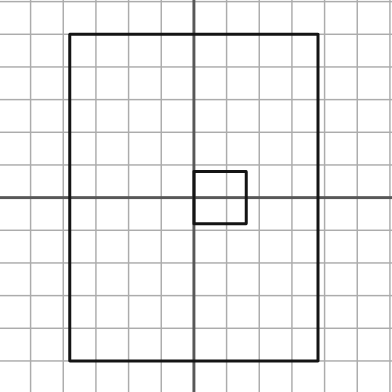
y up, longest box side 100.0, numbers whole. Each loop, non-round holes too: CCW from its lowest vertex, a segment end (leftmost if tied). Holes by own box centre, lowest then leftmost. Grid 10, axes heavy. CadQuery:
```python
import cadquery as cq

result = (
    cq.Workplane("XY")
    .moveTo(-38.0, -50.0)
    .lineTo(38.0, -50.0)
    .lineTo(38.0, 50.0)
    .lineTo(-38.0, 50.0)
    .close()
    .moveTo(0.0, -8.0)
    .lineTo(16.0, -8.0)
    .lineTo(16.0, 8.0)
    .lineTo(0.0, 8.0)
    .close()
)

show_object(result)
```